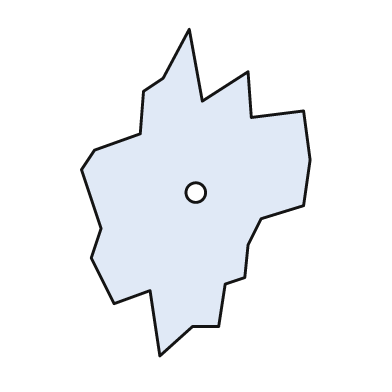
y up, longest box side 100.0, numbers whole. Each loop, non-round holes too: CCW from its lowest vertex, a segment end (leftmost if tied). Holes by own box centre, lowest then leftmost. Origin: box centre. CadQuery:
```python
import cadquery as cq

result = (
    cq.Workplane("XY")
    .moveTo(-11.0, -50.0)
    .lineTo(-1.0, -41.0)
    .lineTo(7.0, -41.0)
    .lineTo(9.0, -28.0)
    .lineTo(15.0, -26.0)
    .lineTo(16.0, -16.0)
    .lineTo(20.0, -8.0)
    .lineTo(33.0, -4.0)
    .lineTo(35.0, 10.0)
    .lineTo(33.0, 25.0)
    .lineTo(17.0, 23.0)
    .lineTo(16.0, 37.0)
    .lineTo(2.0, 28.0)
    .lineTo(-2.0, 50.0)
    .lineTo(-10.0, 35.0)
    .lineTo(-16.0, 31.0)
    .lineTo(-17.0, 18.0)
    .lineTo(-31.0, 13.0)
    .lineTo(-35.0, 7.0)
    .lineTo(-29.0, -11.0)
    .lineTo(-32.0, -20.0)
    .lineTo(-25.0, -34.0)
    .lineTo(-14.0, -30.0)
    .close()
    .moveTo(0.0, 0.0)
    .circle(3.0)
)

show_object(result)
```